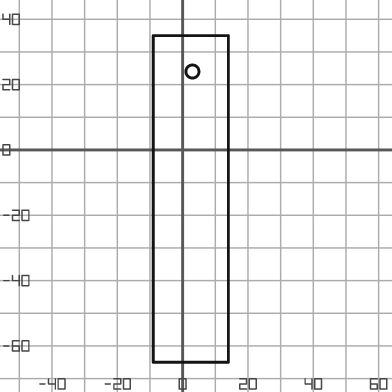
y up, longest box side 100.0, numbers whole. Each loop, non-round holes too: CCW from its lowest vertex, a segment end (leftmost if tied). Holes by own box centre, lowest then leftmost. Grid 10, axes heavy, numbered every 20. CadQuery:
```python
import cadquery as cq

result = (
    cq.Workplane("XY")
    .moveTo(-9.0, -65.0)
    .lineTo(14.0, -65.0)
    .lineTo(14.0, 35.0)
    .lineTo(-9.0, 35.0)
    .close()
    .moveTo(3.0, 24.0)
    .circle(2.0)
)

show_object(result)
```